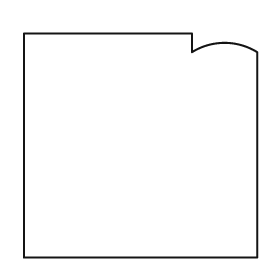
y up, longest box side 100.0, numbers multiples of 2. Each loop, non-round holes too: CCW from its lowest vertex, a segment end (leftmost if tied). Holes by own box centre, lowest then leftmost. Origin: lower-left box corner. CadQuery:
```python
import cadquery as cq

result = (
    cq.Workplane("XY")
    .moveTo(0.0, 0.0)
    .lineTo(100.0, 0.0)
    .lineTo(100.0, 88.0)
    .threePointArc((86.0, 92.0), (72.0, 88.0))
    .lineTo(72.0, 96.0)
    .lineTo(0.0, 96.0)
    .close()
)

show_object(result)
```